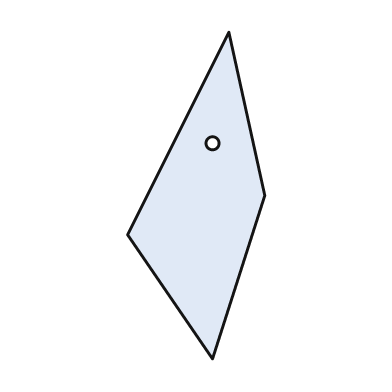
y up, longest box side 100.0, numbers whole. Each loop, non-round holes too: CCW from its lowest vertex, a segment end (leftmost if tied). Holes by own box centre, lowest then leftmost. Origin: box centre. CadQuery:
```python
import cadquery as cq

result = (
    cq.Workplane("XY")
    .moveTo(5.0, -50.0)
    .lineTo(21.0, 0.0)
    .lineTo(10.0, 50.0)
    .lineTo(-21.0, -12.0)
    .close()
    .moveTo(5.0, 16.0)
    .circle(2.0)
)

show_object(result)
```